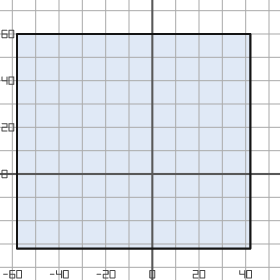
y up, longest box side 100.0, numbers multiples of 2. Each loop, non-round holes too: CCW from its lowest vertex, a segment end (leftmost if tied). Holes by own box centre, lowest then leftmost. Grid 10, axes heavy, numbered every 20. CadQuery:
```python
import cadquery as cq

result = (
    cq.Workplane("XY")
    .moveTo(-58.0, -32.0)
    .lineTo(42.0, -32.0)
    .lineTo(42.0, 60.0)
    .lineTo(-58.0, 60.0)
    .close()
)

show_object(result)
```